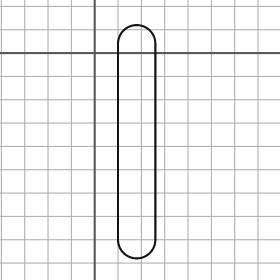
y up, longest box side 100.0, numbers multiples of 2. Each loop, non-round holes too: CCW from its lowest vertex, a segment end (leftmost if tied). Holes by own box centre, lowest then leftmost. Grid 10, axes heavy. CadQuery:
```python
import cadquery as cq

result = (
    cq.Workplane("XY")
    .moveTo(10.0, -80.0)
    .threePointArc((18.0, -88.0), (26.0, -80.0))
    .lineTo(26.0, 4.0)
    .threePointArc((18.0, 12.0), (10.0, 4.0))
    .close()
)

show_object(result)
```